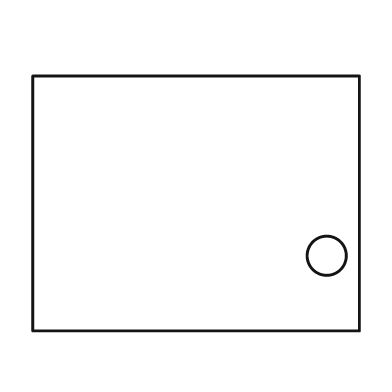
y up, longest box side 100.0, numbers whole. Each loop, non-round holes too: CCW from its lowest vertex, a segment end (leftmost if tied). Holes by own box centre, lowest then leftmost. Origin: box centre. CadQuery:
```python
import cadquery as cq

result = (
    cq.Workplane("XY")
    .moveTo(-50.0, -39.0)
    .lineTo(50.0, -39.0)
    .lineTo(50.0, 39.0)
    .lineTo(-50.0, 39.0)
    .close()
    .moveTo(40.0, -16.0)
    .circle(6.0)
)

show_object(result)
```